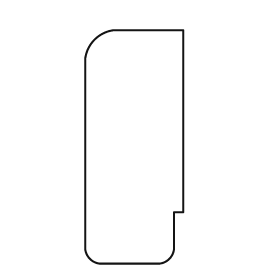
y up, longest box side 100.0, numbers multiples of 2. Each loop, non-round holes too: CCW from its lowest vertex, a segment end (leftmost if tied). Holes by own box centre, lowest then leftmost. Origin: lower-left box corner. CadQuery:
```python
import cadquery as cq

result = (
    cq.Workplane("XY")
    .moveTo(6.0, 0.0)
    .lineTo(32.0, 0.0)
    .threePointArc((36.0, 2.0), (38.0, 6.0))
    .lineTo(38.0, 22.0)
    .lineTo(42.0, 22.0)
    .lineTo(42.0, 100.0)
    .lineTo(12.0, 100.0)
    .threePointArc((4.0, 96.0), (0.0, 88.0))
    .lineTo(0.0, 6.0)
    .threePointArc((2.0, 2.0), (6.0, 0.0))
    .close()
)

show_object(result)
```